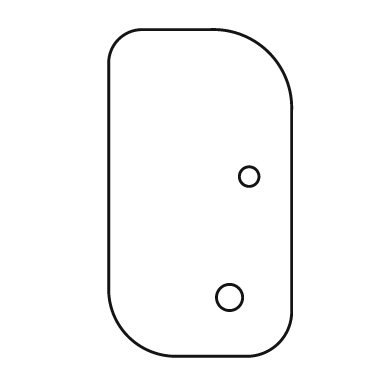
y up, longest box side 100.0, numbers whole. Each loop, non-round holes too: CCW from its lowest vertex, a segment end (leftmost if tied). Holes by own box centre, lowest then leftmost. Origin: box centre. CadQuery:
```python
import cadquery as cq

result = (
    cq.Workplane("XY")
    .moveTo(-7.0, -50.0)
    .lineTo(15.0, -50.0)
    .threePointArc((24.0, -46.0), (28.0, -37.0))
    .lineTo(28.0, 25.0)
    .threePointArc((21.0, 43.0), (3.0, 50.0))
    .lineTo(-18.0, 50.0)
    .threePointArc((-25.0, 47.0), (-28.0, 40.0))
    .lineTo(-28.0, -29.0)
    .threePointArc((-22.0, -44.0), (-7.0, -50.0))
    .close()
    .moveTo(9.0, -32.0)
    .circle(4.0)
    .moveTo(15.0, 5.0)
    .circle(3.0)
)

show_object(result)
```